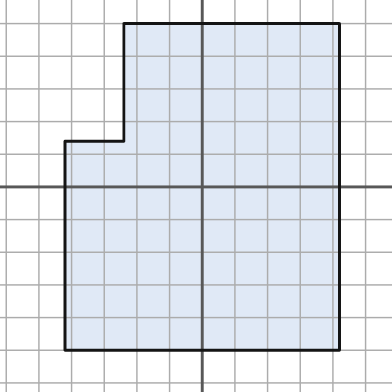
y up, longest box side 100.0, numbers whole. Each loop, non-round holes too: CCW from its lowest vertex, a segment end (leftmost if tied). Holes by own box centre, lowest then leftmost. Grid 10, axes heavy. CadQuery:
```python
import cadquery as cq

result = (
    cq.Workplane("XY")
    .moveTo(-42.0, -50.0)
    .lineTo(42.0, -50.0)
    .lineTo(42.0, 50.0)
    .lineTo(-24.0, 50.0)
    .lineTo(-24.0, 14.0)
    .lineTo(-42.0, 14.0)
    .close()
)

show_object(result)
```